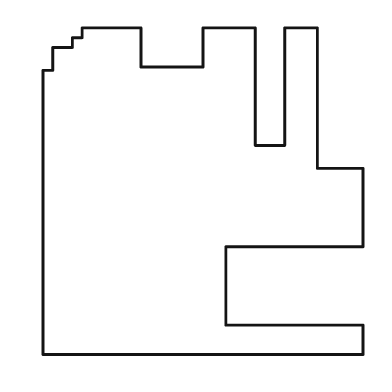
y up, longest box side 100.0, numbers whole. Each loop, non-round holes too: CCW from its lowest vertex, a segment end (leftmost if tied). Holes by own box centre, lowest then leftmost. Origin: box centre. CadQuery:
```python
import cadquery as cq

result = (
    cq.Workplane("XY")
    .moveTo(-49.0, -50.0)
    .lineTo(49.0, -50.0)
    .lineTo(49.0, -41.0)
    .lineTo(7.0, -41.0)
    .lineTo(7.0, -17.0)
    .lineTo(49.0, -17.0)
    .lineTo(49.0, 7.0)
    .lineTo(35.0, 7.0)
    .lineTo(35.0, 50.0)
    .lineTo(25.0, 50.0)
    .lineTo(25.0, 14.0)
    .lineTo(16.0, 14.0)
    .lineTo(16.0, 50.0)
    .lineTo(0.0, 50.0)
    .lineTo(0.0, 38.0)
    .lineTo(-19.0, 38.0)
    .lineTo(-19.0, 50.0)
    .lineTo(-37.0, 50.0)
    .lineTo(-37.0, 47.0)
    .lineTo(-40.0, 47.0)
    .lineTo(-40.0, 44.0)
    .lineTo(-46.0, 44.0)
    .lineTo(-46.0, 37.0)
    .lineTo(-49.0, 37.0)
    .close()
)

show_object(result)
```